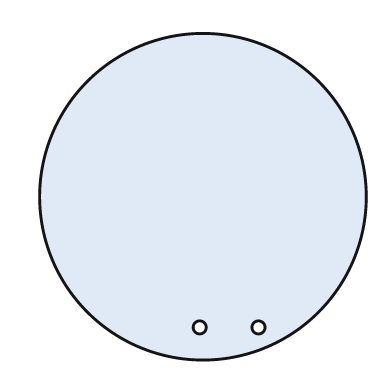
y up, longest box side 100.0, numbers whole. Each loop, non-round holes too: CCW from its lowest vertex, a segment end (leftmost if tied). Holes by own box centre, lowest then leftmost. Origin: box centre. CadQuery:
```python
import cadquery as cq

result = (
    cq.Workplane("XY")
    .moveTo(0.0, 0.0)
    .circle(50.0)
    .moveTo(-1.0, -40.0)
    .circle(2.0)
    .moveTo(17.0, -40.0)
    .circle(2.0)
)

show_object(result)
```